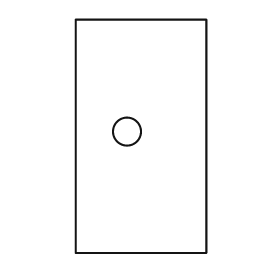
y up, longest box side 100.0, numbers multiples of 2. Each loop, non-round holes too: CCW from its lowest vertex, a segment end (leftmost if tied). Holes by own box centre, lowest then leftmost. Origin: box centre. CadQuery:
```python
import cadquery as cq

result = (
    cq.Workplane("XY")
    .moveTo(-28.0, -50.0)
    .lineTo(28.0, -50.0)
    .lineTo(28.0, 50.0)
    .lineTo(-28.0, 50.0)
    .close()
    .moveTo(-6.0, 2.0)
    .circle(6.0)
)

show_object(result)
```